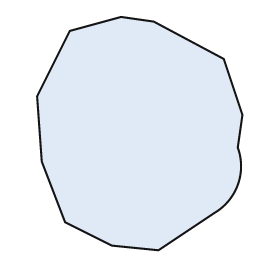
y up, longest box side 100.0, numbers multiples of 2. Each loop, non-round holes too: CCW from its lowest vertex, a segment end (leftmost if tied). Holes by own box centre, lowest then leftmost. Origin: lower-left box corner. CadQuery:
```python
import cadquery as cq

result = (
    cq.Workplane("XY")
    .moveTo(52.0, 0.0)
    .lineTo(76.0, 16.0)
    .threePointArc((86.0, 28.0), (86.0, 44.0))
    .lineTo(88.0, 58.0)
    .lineTo(80.0, 82.0)
    .lineTo(50.0, 98.0)
    .lineTo(36.0, 100.0)
    .lineTo(14.0, 94.0)
    .lineTo(0.0, 66.0)
    .lineTo(2.0, 38.0)
    .lineTo(12.0, 12.0)
    .lineTo(32.0, 2.0)
    .close()
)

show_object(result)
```